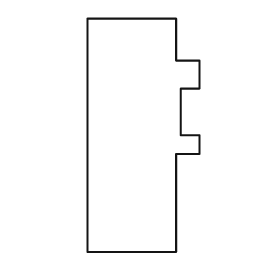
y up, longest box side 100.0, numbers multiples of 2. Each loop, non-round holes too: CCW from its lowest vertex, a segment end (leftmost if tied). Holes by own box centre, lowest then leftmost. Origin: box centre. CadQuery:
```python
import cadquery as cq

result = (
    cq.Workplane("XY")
    .moveTo(-24.0, -50.0)
    .lineTo(14.0, -50.0)
    .lineTo(14.0, -8.0)
    .lineTo(24.0, -8.0)
    .lineTo(24.0, 0.0)
    .lineTo(16.0, 0.0)
    .lineTo(16.0, 20.0)
    .lineTo(24.0, 20.0)
    .lineTo(24.0, 32.0)
    .lineTo(14.0, 32.0)
    .lineTo(14.0, 50.0)
    .lineTo(-24.0, 50.0)
    .close()
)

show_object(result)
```